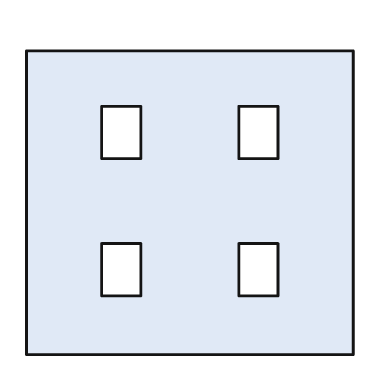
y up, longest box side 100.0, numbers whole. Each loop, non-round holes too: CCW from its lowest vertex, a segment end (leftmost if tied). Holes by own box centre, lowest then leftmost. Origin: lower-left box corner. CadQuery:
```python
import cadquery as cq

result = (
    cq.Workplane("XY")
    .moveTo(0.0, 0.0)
    .lineTo(100.0, 0.0)
    .lineTo(100.0, 93.0)
    .lineTo(0.0, 93.0)
    .close()
    .moveTo(23.0, 18.0)
    .lineTo(35.0, 18.0)
    .lineTo(35.0, 34.0)
    .lineTo(23.0, 34.0)
    .close()
    .moveTo(65.0, 18.0)
    .lineTo(77.0, 18.0)
    .lineTo(77.0, 34.0)
    .lineTo(65.0, 34.0)
    .close()
    .moveTo(23.0, 60.0)
    .lineTo(35.0, 60.0)
    .lineTo(35.0, 76.0)
    .lineTo(23.0, 76.0)
    .close()
    .moveTo(65.0, 60.0)
    .lineTo(77.0, 60.0)
    .lineTo(77.0, 76.0)
    .lineTo(65.0, 76.0)
    .close()
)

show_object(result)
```